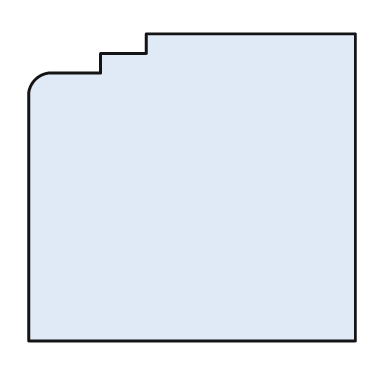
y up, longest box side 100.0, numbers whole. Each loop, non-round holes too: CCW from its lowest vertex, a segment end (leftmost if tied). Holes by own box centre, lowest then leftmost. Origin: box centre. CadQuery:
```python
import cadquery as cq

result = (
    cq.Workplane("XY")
    .moveTo(-50.0, -47.0)
    .lineTo(50.0, -47.0)
    .lineTo(50.0, 47.0)
    .lineTo(-14.0, 47.0)
    .lineTo(-14.0, 41.0)
    .lineTo(-28.0, 41.0)
    .lineTo(-28.0, 35.0)
    .lineTo(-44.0, 35.0)
    .threePointArc((-48.0, 33.0), (-50.0, 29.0))
    .close()
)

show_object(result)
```